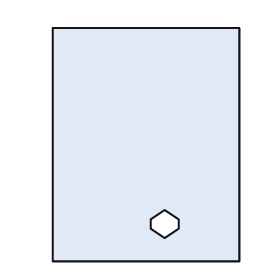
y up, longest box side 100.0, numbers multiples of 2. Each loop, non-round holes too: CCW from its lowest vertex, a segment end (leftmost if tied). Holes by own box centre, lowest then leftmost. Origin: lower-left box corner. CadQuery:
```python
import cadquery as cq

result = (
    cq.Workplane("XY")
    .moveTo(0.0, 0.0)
    .lineTo(80.0, 0.0)
    .lineTo(80.0, 100.0)
    .lineTo(0.0, 100.0)
    .close()
    .moveTo(48.0, 10.0)
    .lineTo(54.0, 14.0)
    .lineTo(54.0, 18.0)
    .lineTo(48.0, 22.0)
    .lineTo(42.0, 18.0)
    .lineTo(42.0, 14.0)
    .close()
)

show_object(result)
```